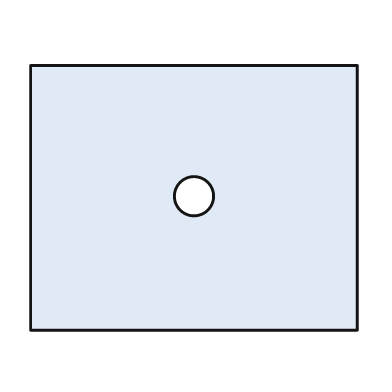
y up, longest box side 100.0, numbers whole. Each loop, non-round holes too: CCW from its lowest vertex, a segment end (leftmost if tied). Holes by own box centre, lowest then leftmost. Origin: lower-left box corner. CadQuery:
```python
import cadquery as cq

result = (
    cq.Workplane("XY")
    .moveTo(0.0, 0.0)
    .lineTo(100.0, 0.0)
    .lineTo(100.0, 81.0)
    .lineTo(0.0, 81.0)
    .close()
    .moveTo(50.0, 41.0)
    .circle(6.0)
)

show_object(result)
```